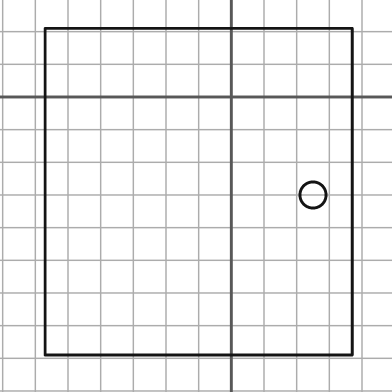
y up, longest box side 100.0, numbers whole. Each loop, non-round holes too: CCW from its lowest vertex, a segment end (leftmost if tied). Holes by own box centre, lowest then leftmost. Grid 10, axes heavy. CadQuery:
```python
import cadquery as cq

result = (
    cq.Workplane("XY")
    .moveTo(-57.0, -79.0)
    .lineTo(37.0, -79.0)
    .lineTo(37.0, 21.0)
    .lineTo(-57.0, 21.0)
    .close()
    .moveTo(25.0, -30.0)
    .circle(4.0)
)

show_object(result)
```